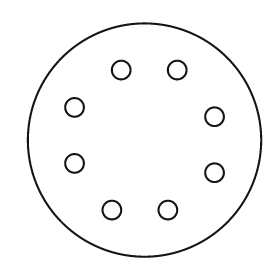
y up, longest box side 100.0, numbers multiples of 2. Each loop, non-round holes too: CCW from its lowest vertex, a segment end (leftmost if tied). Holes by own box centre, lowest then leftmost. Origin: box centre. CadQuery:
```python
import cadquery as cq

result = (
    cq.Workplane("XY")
    .moveTo(0.0, 0.0)
    .circle(50.0)
    .moveTo(-14.0, -30.0)
    .circle(4.0)
    .moveTo(10.0, -30.0)
    .circle(4.0)
    .moveTo(30.0, -14.0)
    .circle(4.0)
    .moveTo(-30.0, -10.0)
    .circle(4.0)
    .moveTo(30.0, 10.0)
    .circle(4.0)
    .moveTo(-30.0, 14.0)
    .circle(4.0)
    .moveTo(-10.0, 30.0)
    .circle(4.0)
    .moveTo(14.0, 30.0)
    .circle(4.0)
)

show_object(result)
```